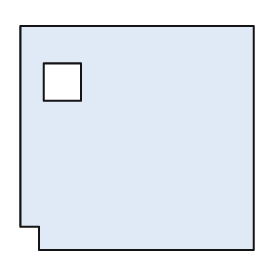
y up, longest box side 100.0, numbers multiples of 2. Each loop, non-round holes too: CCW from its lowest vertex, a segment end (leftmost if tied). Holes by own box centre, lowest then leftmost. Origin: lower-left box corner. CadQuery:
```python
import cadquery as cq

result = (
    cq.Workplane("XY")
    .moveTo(8.0, 0.0)
    .lineTo(100.0, 0.0)
    .lineTo(100.0, 96.0)
    .lineTo(0.0, 96.0)
    .lineTo(0.0, 10.0)
    .lineTo(8.0, 10.0)
    .close()
    .moveTo(10.0, 64.0)
    .lineTo(26.0, 64.0)
    .lineTo(26.0, 80.0)
    .lineTo(10.0, 80.0)
    .close()
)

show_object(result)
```